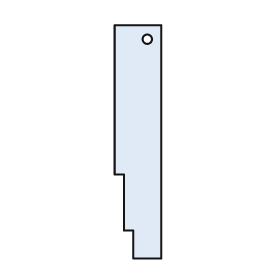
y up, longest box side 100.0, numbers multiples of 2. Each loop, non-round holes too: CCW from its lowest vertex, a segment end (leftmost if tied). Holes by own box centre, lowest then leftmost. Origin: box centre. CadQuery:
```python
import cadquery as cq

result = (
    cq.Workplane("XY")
    .moveTo(-2.0, -50.0)
    .lineTo(10.0, -50.0)
    .lineTo(10.0, 50.0)
    .lineTo(-10.0, 50.0)
    .lineTo(-10.0, -14.0)
    .lineTo(-6.0, -14.0)
    .lineTo(-6.0, -38.0)
    .lineTo(-2.0, -38.0)
    .close()
    .moveTo(4.0, 44.0)
    .circle(2.0)
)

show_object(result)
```